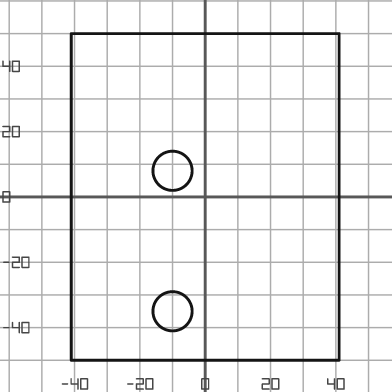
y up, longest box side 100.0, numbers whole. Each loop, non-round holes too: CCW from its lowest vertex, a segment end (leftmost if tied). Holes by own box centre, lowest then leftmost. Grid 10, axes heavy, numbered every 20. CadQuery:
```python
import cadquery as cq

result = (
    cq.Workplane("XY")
    .moveTo(-41.0, -50.0)
    .lineTo(41.0, -50.0)
    .lineTo(41.0, 50.0)
    .lineTo(-41.0, 50.0)
    .close()
    .moveTo(-10.0, -35.0)
    .circle(6.0)
    .moveTo(-10.0, 8.0)
    .circle(6.0)
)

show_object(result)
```